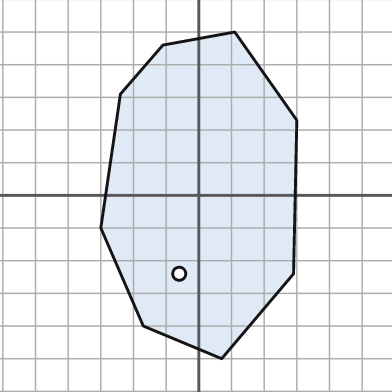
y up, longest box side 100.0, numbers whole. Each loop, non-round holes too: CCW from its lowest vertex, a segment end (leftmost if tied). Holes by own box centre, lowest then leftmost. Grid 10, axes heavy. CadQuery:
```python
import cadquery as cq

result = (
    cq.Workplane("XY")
    .moveTo(7.0, -50.0)
    .lineTo(29.0, -24.0)
    .lineTo(30.0, 23.0)
    .lineTo(11.0, 50.0)
    .lineTo(-11.0, 46.0)
    .lineTo(-24.0, 31.0)
    .lineTo(-30.0, -10.0)
    .lineTo(-17.0, -40.0)
    .close()
    .moveTo(-6.0, -24.0)
    .circle(2.0)
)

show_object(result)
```